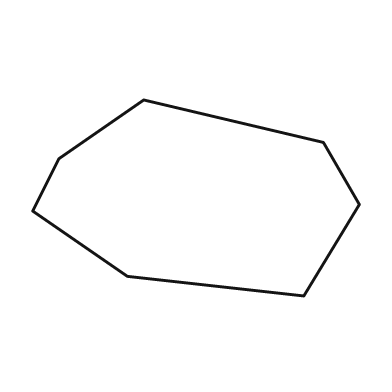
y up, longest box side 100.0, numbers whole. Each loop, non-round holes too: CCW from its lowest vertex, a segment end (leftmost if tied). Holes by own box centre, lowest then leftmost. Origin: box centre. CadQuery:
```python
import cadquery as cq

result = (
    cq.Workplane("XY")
    .moveTo(33.0, -30.0)
    .lineTo(50.0, -2.0)
    .lineTo(39.0, 17.0)
    .lineTo(-16.0, 30.0)
    .lineTo(-42.0, 12.0)
    .lineTo(-50.0, -4.0)
    .lineTo(-21.0, -24.0)
    .close()
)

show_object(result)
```